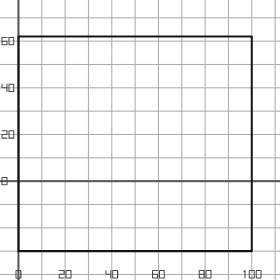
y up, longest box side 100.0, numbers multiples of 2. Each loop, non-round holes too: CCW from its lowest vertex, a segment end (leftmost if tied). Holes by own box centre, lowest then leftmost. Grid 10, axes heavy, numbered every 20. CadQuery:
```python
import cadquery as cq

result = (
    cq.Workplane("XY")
    .moveTo(0.0, -30.0)
    .lineTo(100.0, -30.0)
    .lineTo(100.0, 62.0)
    .lineTo(0.0, 62.0)
    .close()
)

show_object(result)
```